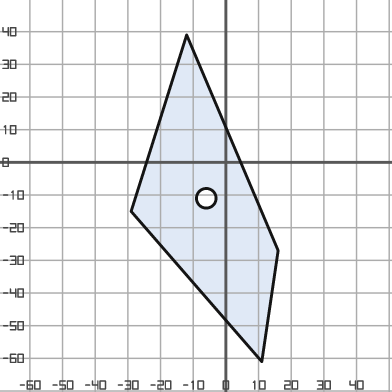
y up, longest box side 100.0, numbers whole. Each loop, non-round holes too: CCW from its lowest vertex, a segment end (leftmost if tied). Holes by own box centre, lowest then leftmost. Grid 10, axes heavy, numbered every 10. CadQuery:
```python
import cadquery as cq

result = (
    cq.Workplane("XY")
    .moveTo(11.0, -61.0)
    .lineTo(16.0, -27.0)
    .lineTo(-12.0, 39.0)
    .lineTo(-29.0, -15.0)
    .close()
    .moveTo(-6.0, -11.0)
    .circle(3.0)
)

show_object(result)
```